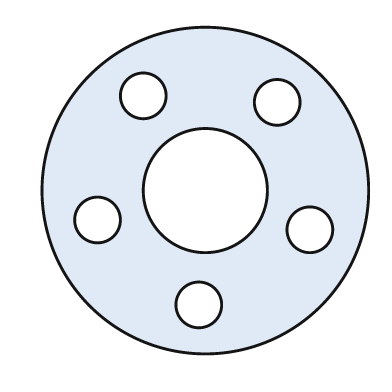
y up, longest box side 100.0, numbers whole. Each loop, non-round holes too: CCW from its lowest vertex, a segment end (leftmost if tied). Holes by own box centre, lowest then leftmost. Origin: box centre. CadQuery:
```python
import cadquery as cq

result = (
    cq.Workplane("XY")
    .moveTo(0.0, 0.0)
    .circle(50.0)
    .moveTo(-2.0, -35.0)
    .circle(7.0)
    .moveTo(32.0, -12.0)
    .circle(7.0)
    .moveTo(-33.0, -9.0)
    .circle(7.0)
    .moveTo(0.0, 0.0)
    .circle(19.0)
    .moveTo(22.0, 27.0)
    .circle(7.0)
    .moveTo(-19.0, 29.0)
    .circle(7.0)
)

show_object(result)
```